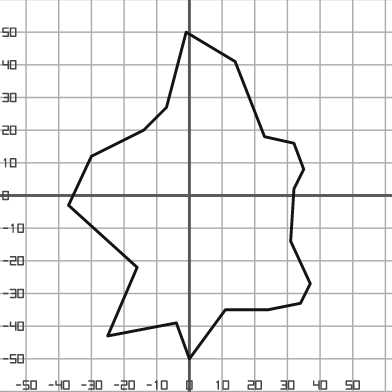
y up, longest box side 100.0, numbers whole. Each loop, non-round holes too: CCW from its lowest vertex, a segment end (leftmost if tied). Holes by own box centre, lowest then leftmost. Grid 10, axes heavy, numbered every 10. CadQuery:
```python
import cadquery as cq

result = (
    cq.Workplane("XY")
    .moveTo(0.0, -50.0)
    .lineTo(11.0, -35.0)
    .lineTo(24.0, -35.0)
    .lineTo(34.0, -33.0)
    .lineTo(37.0, -27.0)
    .lineTo(31.0, -14.0)
    .lineTo(32.0, 2.0)
    .lineTo(35.0, 8.0)
    .lineTo(32.0, 16.0)
    .lineTo(23.0, 18.0)
    .lineTo(14.0, 41.0)
    .lineTo(-1.0, 50.0)
    .lineTo(-7.0, 27.0)
    .lineTo(-14.0, 20.0)
    .lineTo(-30.0, 12.0)
    .lineTo(-37.0, -3.0)
    .lineTo(-16.0, -22.0)
    .lineTo(-25.0, -43.0)
    .lineTo(-4.0, -39.0)
    .close()
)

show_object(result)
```